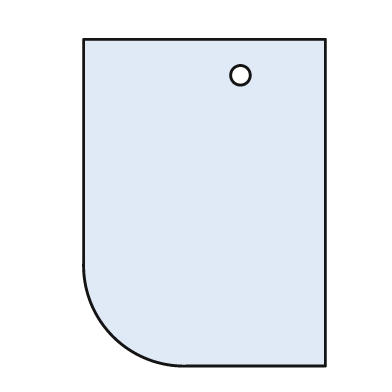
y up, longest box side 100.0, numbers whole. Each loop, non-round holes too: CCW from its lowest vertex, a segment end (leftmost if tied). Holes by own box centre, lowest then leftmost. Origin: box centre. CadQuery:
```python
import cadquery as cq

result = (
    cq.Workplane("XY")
    .moveTo(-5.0, -50.0)
    .lineTo(37.0, -50.0)
    .lineTo(37.0, 50.0)
    .lineTo(-37.0, 50.0)
    .lineTo(-37.0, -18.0)
    .threePointArc((-28.0, -41.0), (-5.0, -50.0))
    .close()
    .moveTo(11.0, 39.0)
    .circle(3.0)
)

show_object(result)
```